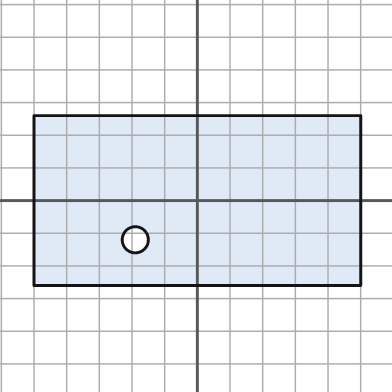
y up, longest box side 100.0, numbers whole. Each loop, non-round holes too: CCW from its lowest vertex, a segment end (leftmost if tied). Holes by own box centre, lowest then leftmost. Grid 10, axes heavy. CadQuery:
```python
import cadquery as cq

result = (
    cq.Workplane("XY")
    .moveTo(-50.0, -26.0)
    .lineTo(50.0, -26.0)
    .lineTo(50.0, 26.0)
    .lineTo(-50.0, 26.0)
    .close()
    .moveTo(-19.0, -12.0)
    .circle(4.0)
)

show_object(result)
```